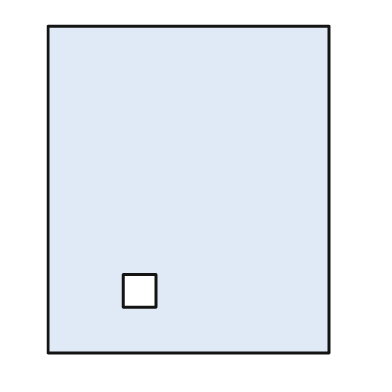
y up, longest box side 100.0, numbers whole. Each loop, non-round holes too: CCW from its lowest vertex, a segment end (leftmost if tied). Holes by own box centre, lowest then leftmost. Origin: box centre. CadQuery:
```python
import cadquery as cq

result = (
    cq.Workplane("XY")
    .moveTo(-43.0, -50.0)
    .lineTo(43.0, -50.0)
    .lineTo(43.0, 50.0)
    .lineTo(-43.0, 50.0)
    .close()
    .moveTo(-20.0, -36.0)
    .lineTo(-10.0, -36.0)
    .lineTo(-10.0, -26.0)
    .lineTo(-20.0, -26.0)
    .close()
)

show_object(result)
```